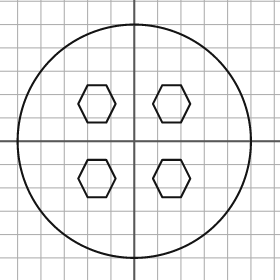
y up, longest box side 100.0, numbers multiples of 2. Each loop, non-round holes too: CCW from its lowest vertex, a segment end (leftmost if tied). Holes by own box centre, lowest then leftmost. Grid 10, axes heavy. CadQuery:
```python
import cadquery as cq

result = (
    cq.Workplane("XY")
    .moveTo(0.0, 0.0)
    .circle(50.0)
    .moveTo(-20.0, -24.0)
    .lineTo(-12.0, -24.0)
    .lineTo(-8.0, -16.0)
    .lineTo(-12.0, -8.0)
    .lineTo(-20.0, -8.0)
    .lineTo(-24.0, -16.0)
    .close()
    .moveTo(12.0, -24.0)
    .lineTo(20.0, -24.0)
    .lineTo(24.0, -16.0)
    .lineTo(20.0, -8.0)
    .lineTo(12.0, -8.0)
    .lineTo(8.0, -16.0)
    .close()
    .moveTo(-20.0, 8.0)
    .lineTo(-12.0, 8.0)
    .lineTo(-8.0, 16.0)
    .lineTo(-12.0, 24.0)
    .lineTo(-20.0, 24.0)
    .lineTo(-24.0, 16.0)
    .close()
    .moveTo(12.0, 8.0)
    .lineTo(20.0, 8.0)
    .lineTo(24.0, 16.0)
    .lineTo(20.0, 24.0)
    .lineTo(12.0, 24.0)
    .lineTo(8.0, 16.0)
    .close()
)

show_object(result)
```